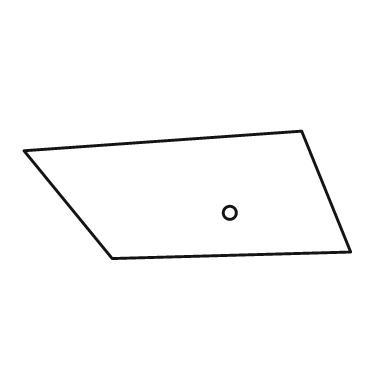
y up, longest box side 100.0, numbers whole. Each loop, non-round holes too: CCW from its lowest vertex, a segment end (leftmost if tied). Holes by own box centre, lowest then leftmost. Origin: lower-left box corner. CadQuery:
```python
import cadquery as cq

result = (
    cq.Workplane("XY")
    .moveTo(27.0, 0.0)
    .lineTo(100.0, 2.0)
    .lineTo(85.0, 39.0)
    .lineTo(0.0, 33.0)
    .close()
    .moveTo(63.0, 14.0)
    .circle(2.0)
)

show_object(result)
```